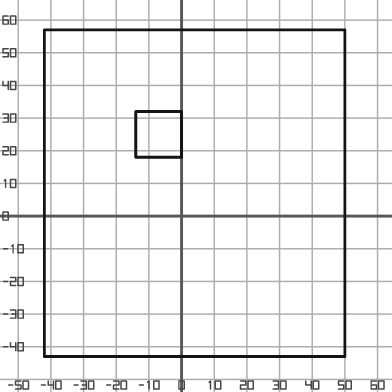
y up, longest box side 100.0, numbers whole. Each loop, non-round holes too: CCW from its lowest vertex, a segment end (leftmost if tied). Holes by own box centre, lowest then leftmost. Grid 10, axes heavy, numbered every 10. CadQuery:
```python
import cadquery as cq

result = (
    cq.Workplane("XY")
    .moveTo(-42.0, -43.0)
    .lineTo(50.0, -43.0)
    .lineTo(50.0, 57.0)
    .lineTo(-42.0, 57.0)
    .close()
    .moveTo(-14.0, 18.0)
    .lineTo(0.0, 18.0)
    .lineTo(0.0, 32.0)
    .lineTo(-14.0, 32.0)
    .close()
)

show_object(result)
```